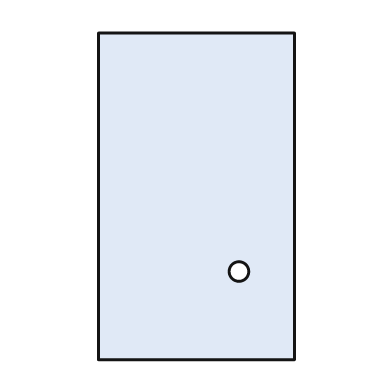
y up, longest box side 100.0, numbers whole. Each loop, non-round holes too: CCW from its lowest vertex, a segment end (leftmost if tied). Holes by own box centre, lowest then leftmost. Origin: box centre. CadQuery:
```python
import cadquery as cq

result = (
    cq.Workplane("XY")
    .moveTo(-30.0, -50.0)
    .lineTo(30.0, -50.0)
    .lineTo(30.0, 50.0)
    .lineTo(-30.0, 50.0)
    .close()
    .moveTo(13.0, -23.0)
    .circle(3.0)
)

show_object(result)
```